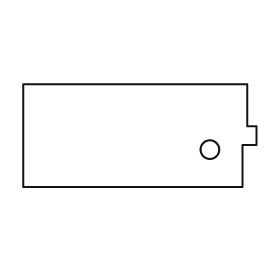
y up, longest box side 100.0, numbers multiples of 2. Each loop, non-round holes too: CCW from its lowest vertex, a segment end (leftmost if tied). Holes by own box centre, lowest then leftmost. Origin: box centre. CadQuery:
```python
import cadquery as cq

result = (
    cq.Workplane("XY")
    .moveTo(-50.0, -22.0)
    .lineTo(44.0, -22.0)
    .lineTo(44.0, -4.0)
    .lineTo(50.0, -4.0)
    .lineTo(50.0, 4.0)
    .lineTo(46.0, 4.0)
    .lineTo(46.0, 22.0)
    .lineTo(-50.0, 22.0)
    .close()
    .moveTo(30.0, -6.0)
    .circle(4.0)
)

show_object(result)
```